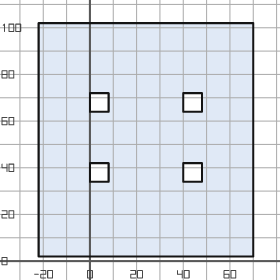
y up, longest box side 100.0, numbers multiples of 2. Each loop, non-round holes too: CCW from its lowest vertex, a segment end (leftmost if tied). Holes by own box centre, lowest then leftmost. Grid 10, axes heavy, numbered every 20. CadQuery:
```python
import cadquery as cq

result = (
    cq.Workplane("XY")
    .moveTo(-22.0, 2.0)
    .lineTo(70.0, 2.0)
    .lineTo(70.0, 102.0)
    .lineTo(-22.0, 102.0)
    .close()
    .moveTo(0.0, 34.0)
    .lineTo(8.0, 34.0)
    .lineTo(8.0, 42.0)
    .lineTo(0.0, 42.0)
    .close()
    .moveTo(40.0, 34.0)
    .lineTo(48.0, 34.0)
    .lineTo(48.0, 42.0)
    .lineTo(40.0, 42.0)
    .close()
    .moveTo(0.0, 64.0)
    .lineTo(8.0, 64.0)
    .lineTo(8.0, 72.0)
    .lineTo(0.0, 72.0)
    .close()
    .moveTo(40.0, 64.0)
    .lineTo(48.0, 64.0)
    .lineTo(48.0, 72.0)
    .lineTo(40.0, 72.0)
    .close()
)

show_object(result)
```